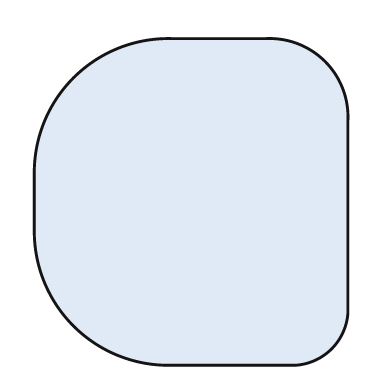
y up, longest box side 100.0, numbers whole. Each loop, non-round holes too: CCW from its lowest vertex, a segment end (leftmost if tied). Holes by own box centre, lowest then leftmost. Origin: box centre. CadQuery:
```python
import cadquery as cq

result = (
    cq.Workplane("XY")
    .moveTo(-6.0, -50.0)
    .lineTo(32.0, -50.0)
    .threePointArc((43.0, -45.0), (48.0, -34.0))
    .lineTo(48.0, 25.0)
    .threePointArc((41.0, 43.0), (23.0, 50.0))
    .lineTo(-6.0, 50.0)
    .threePointArc((-36.0, 38.0), (-48.0, 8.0))
    .lineTo(-48.0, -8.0)
    .threePointArc((-36.0, -38.0), (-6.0, -50.0))
    .close()
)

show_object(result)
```